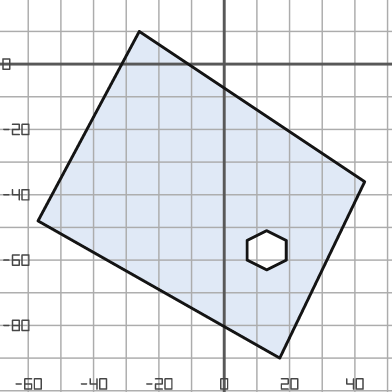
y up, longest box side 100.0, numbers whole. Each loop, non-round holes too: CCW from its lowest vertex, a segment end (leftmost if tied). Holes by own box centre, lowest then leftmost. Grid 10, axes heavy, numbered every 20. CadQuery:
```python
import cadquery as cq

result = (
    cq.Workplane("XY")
    .moveTo(17.0, -90.0)
    .lineTo(43.0, -36.0)
    .lineTo(-26.0, 10.0)
    .lineTo(-57.0, -48.0)
    .close()
    .moveTo(13.0, -63.0)
    .lineTo(19.0, -60.0)
    .lineTo(19.0, -54.0)
    .lineTo(13.0, -51.0)
    .lineTo(7.0, -54.0)
    .lineTo(7.0, -60.0)
    .close()
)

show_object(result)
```